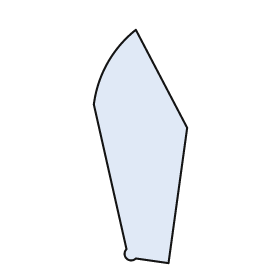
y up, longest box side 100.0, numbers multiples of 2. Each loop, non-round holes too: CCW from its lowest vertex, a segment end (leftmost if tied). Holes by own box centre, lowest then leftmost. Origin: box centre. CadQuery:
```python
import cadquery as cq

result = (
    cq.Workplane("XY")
    .moveTo(12.0, -50.0)
    .lineTo(20.0, 8.0)
    .lineTo(-2.0, 50.0)
    .threePointArc((-14.0, 36.0), (-20.0, 18.0))
    .lineTo(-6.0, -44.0)
    .threePointArc((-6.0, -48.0), (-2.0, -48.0))
    .close()
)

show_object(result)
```